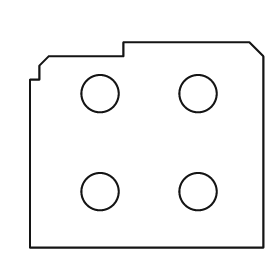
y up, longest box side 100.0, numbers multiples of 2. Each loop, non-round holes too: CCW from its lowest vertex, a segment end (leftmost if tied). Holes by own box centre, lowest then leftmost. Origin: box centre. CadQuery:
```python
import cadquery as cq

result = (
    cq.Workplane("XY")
    .moveTo(-50.0, -44.0)
    .lineTo(50.0, -44.0)
    .lineTo(50.0, 38.0)
    .lineTo(44.0, 44.0)
    .lineTo(-10.0, 44.0)
    .lineTo(-10.0, 38.0)
    .lineTo(-42.0, 38.0)
    .lineTo(-46.0, 34.0)
    .lineTo(-46.0, 28.0)
    .lineTo(-50.0, 28.0)
    .close()
    .moveTo(-20.0, -20.0)
    .circle(8.0)
    .moveTo(22.0, -20.0)
    .circle(8.0)
    .moveTo(-20.0, 22.0)
    .circle(8.0)
    .moveTo(22.0, 22.0)
    .circle(8.0)
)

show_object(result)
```